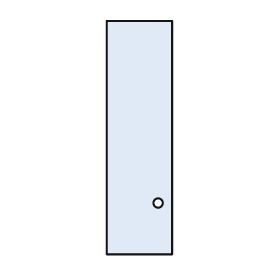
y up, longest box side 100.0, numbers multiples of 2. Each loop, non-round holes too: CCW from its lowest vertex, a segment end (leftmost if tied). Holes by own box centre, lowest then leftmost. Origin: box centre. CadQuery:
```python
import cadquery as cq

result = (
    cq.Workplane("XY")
    .moveTo(-14.0, -50.0)
    .lineTo(14.0, -50.0)
    .lineTo(14.0, 50.0)
    .lineTo(-14.0, 50.0)
    .close()
    .moveTo(8.0, -28.0)
    .circle(2.0)
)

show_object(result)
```